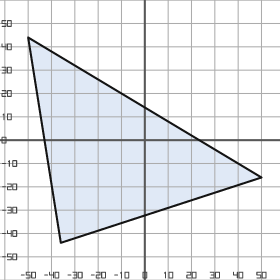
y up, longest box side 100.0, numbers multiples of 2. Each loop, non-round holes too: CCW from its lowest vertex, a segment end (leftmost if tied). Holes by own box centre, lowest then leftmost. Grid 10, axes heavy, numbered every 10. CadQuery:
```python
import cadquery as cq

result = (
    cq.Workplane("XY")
    .moveTo(-36.0, -44.0)
    .lineTo(50.0, -16.0)
    .lineTo(-50.0, 44.0)
    .close()
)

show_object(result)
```